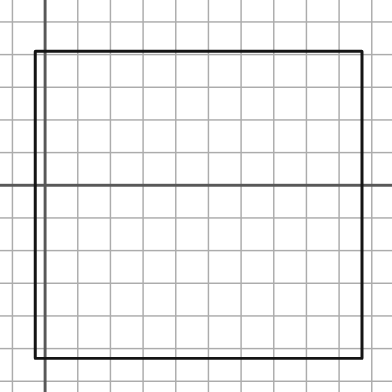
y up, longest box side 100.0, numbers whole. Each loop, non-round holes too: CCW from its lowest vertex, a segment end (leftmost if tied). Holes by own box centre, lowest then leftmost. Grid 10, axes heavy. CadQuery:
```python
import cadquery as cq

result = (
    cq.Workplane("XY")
    .moveTo(-3.0, -53.0)
    .lineTo(97.0, -53.0)
    .lineTo(97.0, 41.0)
    .lineTo(-3.0, 41.0)
    .close()
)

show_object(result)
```